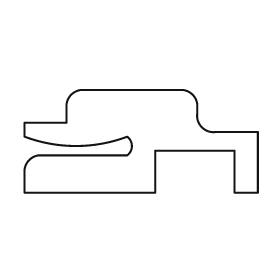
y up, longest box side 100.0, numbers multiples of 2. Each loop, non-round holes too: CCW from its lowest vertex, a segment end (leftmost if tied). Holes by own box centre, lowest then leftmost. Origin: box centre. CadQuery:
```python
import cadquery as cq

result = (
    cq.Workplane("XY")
    .moveTo(-50.0, -22.0)
    .lineTo(6.0, -22.0)
    .lineTo(6.0, -4.0)
    .lineTo(40.0, -4.0)
    .lineTo(40.0, -22.0)
    .lineTo(50.0, -22.0)
    .lineTo(50.0, 4.0)
    .lineTo(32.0, 4.0)
    .threePointArc((26.0, 6.0), (24.0, 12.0))
    .lineTo(24.0, 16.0)
    .threePointArc((22.0, 20.0), (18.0, 22.0))
    .lineTo(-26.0, 22.0)
    .threePointArc((-30.0, 20.0), (-32.0, 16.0))
    .lineTo(-32.0, 8.0)
    .lineTo(-50.0, 8.0)
    .lineTo(-50.0, 2.0)
    .threePointArc((-28.0, -2.0), (-6.0, 2.0))
    .threePointArc((-4.0, -2.0), (-6.0, -6.0))
    .lineTo(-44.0, -6.0)
    .threePointArc((-48.0, -8.0), (-50.0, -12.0))
    .close()
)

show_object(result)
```